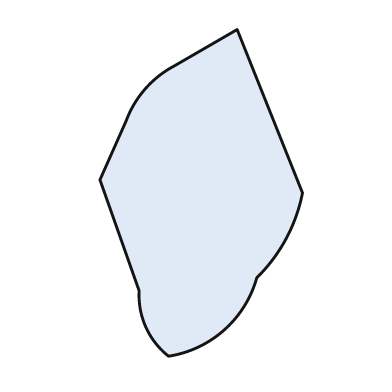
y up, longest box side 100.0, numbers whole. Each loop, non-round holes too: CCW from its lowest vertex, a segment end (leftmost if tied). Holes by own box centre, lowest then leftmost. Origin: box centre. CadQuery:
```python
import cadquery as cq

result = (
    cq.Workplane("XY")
    .moveTo(-10.0, -50.0)
    .threePointArc((7.0, -42.0), (17.0, -26.0))
    .threePointArc((26.0, -14.0), (31.0, 0.0))
    .lineTo(11.0, 50.0)
    .lineTo(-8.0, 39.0)
    .threePointArc((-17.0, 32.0), (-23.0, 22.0))
    .lineTo(-31.0, 4.0)
    .lineTo(-19.0, -30.0)
    .threePointArc((-17.0, -41.0), (-10.0, -50.0))
    .close()
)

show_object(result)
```